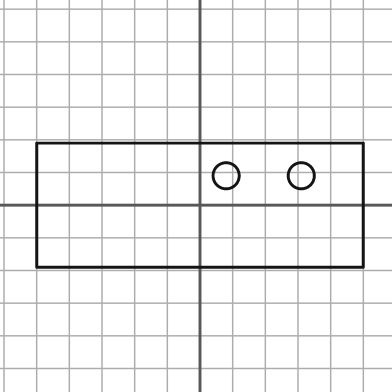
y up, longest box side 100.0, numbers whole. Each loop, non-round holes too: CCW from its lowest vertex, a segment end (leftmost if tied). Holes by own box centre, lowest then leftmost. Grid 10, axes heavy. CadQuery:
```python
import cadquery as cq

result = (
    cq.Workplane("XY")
    .moveTo(-50.0, -19.0)
    .lineTo(50.0, -19.0)
    .lineTo(50.0, 19.0)
    .lineTo(-50.0, 19.0)
    .close()
    .moveTo(8.0, 9.0)
    .circle(4.0)
    .moveTo(31.0, 9.0)
    .circle(4.0)
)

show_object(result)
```